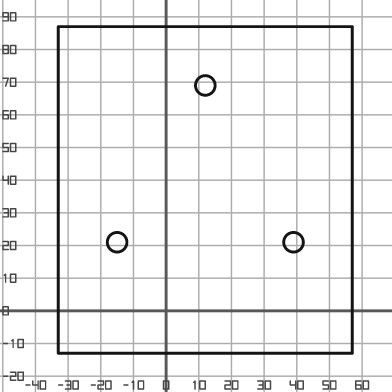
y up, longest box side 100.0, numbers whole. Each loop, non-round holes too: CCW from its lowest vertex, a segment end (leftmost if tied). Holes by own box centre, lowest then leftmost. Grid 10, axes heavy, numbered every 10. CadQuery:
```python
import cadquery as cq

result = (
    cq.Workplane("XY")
    .moveTo(-33.0, -13.0)
    .lineTo(57.0, -13.0)
    .lineTo(57.0, 87.0)
    .lineTo(-33.0, 87.0)
    .close()
    .moveTo(-15.0, 21.0)
    .circle(3.0)
    .moveTo(39.0, 21.0)
    .circle(3.0)
    .moveTo(12.0, 69.0)
    .circle(3.0)
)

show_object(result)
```